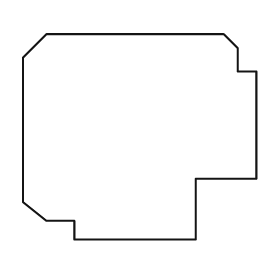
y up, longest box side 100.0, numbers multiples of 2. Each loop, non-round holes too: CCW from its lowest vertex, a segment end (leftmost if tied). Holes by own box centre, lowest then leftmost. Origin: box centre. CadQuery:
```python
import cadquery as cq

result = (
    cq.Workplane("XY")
    .moveTo(-28.0, -44.0)
    .lineTo(24.0, -44.0)
    .lineTo(24.0, -18.0)
    .lineTo(50.0, -18.0)
    .lineTo(50.0, 28.0)
    .lineTo(42.0, 28.0)
    .lineTo(42.0, 38.0)
    .lineTo(36.0, 44.0)
    .lineTo(-40.0, 44.0)
    .lineTo(-50.0, 34.0)
    .lineTo(-50.0, -28.0)
    .lineTo(-40.0, -36.0)
    .lineTo(-28.0, -36.0)
    .close()
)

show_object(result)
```